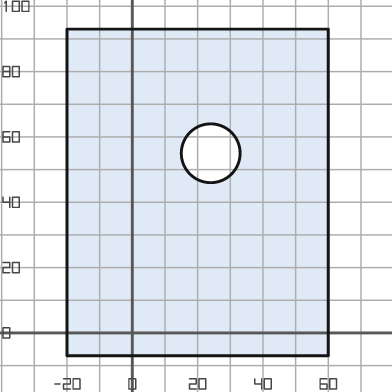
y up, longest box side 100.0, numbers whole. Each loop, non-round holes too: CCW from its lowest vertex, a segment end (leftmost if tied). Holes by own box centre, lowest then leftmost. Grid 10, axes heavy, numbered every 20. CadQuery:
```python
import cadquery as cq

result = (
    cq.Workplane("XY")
    .moveTo(-20.0, -7.0)
    .lineTo(60.0, -7.0)
    .lineTo(60.0, 93.0)
    .lineTo(-20.0, 93.0)
    .close()
    .moveTo(24.0, 55.0)
    .circle(9.0)
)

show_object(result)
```